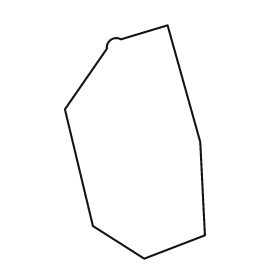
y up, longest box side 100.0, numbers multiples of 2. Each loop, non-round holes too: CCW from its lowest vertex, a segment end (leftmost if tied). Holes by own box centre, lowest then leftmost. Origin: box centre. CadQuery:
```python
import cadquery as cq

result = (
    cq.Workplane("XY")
    .moveTo(4.0, -50.0)
    .lineTo(30.0, -40.0)
    .lineTo(28.0, 0.0)
    .lineTo(14.0, 50.0)
    .lineTo(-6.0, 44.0)
    .threePointArc((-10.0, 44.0), (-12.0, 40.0))
    .lineTo(-30.0, 14.0)
    .lineTo(-18.0, -36.0)
    .close()
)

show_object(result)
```